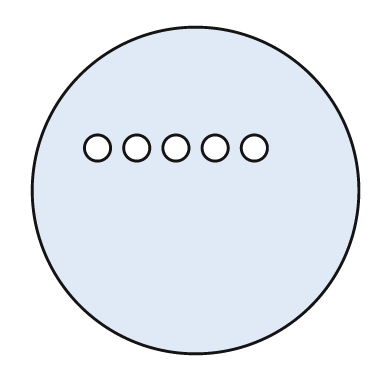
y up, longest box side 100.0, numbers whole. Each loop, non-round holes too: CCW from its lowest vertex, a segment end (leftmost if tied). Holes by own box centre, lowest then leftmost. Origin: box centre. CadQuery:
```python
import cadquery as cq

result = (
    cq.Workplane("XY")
    .moveTo(0.0, 0.0)
    .circle(50.0)
    .moveTo(-30.0, 13.0)
    .circle(4.0)
    .moveTo(-18.0, 13.0)
    .circle(4.0)
    .moveTo(-6.0, 13.0)
    .circle(4.0)
    .moveTo(6.0, 13.0)
    .circle(4.0)
    .moveTo(18.0, 13.0)
    .circle(4.0)
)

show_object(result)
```